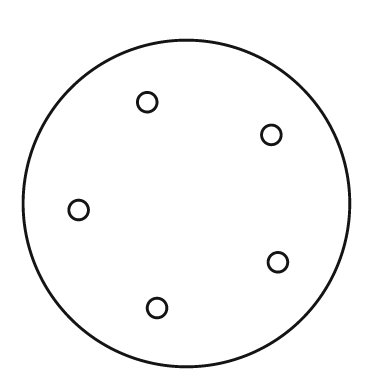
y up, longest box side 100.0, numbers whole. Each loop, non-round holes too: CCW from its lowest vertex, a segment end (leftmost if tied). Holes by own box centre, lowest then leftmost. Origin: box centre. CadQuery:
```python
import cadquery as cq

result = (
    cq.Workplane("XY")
    .moveTo(0.0, 0.0)
    .circle(50.0)
    .moveTo(-9.0, -32.0)
    .circle(3.0)
    .moveTo(28.0, -18.0)
    .circle(3.0)
    .moveTo(-33.0, -2.0)
    .circle(3.0)
    .moveTo(26.0, 21.0)
    .circle(3.0)
    .moveTo(-12.0, 31.0)
    .circle(3.0)
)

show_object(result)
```